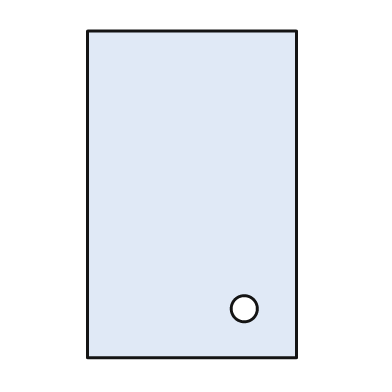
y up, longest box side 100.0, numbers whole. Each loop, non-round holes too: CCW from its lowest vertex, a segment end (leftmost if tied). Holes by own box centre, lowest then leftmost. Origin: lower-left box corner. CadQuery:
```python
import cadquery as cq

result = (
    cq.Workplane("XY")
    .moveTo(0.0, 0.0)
    .lineTo(64.0, 0.0)
    .lineTo(64.0, 100.0)
    .lineTo(0.0, 100.0)
    .close()
    .moveTo(48.0, 15.0)
    .circle(4.0)
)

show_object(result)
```